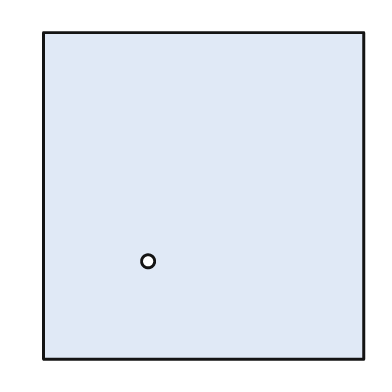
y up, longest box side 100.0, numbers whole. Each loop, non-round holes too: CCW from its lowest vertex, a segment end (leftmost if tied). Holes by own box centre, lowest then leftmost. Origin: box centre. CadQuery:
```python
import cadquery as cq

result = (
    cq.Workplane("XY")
    .moveTo(-49.0, -50.0)
    .lineTo(49.0, -50.0)
    .lineTo(49.0, 50.0)
    .lineTo(-49.0, 50.0)
    .close()
    .moveTo(-17.0, -20.0)
    .circle(2.0)
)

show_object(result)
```